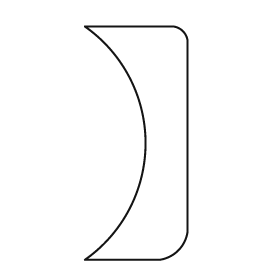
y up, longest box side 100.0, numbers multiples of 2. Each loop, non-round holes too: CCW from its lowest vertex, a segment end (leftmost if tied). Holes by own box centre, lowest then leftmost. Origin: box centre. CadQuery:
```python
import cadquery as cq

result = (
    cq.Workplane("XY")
    .moveTo(-22.0, -50.0)
    .lineTo(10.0, -50.0)
    .threePointArc((18.0, -46.0), (22.0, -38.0))
    .lineTo(22.0, 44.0)
    .threePointArc((20.0, 48.0), (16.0, 50.0))
    .lineTo(-22.0, 50.0)
    .threePointArc((4.0, 0.0), (-22.0, -50.0))
    .close()
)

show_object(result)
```